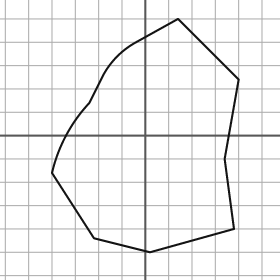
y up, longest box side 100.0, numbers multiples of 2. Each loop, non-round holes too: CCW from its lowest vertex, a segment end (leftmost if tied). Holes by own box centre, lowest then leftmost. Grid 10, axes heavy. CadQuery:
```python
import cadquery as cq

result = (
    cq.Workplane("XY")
    .moveTo(2.0, -50.0)
    .lineTo(38.0, -40.0)
    .lineTo(34.0, -10.0)
    .lineTo(40.0, 24.0)
    .lineTo(14.0, 50.0)
    .lineTo(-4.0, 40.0)
    .threePointArc((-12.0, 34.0), (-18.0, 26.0))
    .lineTo(-24.0, 14.0)
    .threePointArc((-34.0, 0.0), (-40.0, -16.0))
    .lineTo(-22.0, -44.0)
    .close()
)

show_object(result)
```